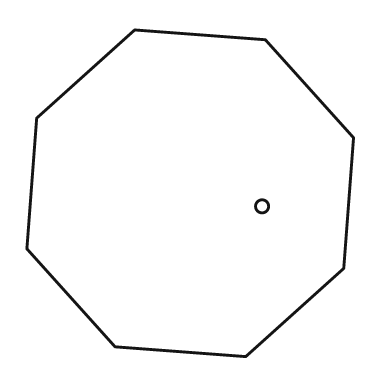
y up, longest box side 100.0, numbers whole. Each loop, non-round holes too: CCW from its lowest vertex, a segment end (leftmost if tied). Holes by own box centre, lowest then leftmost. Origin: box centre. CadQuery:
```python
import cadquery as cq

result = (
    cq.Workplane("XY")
    .moveTo(17.0, -50.0)
    .lineTo(47.0, -23.0)
    .lineTo(50.0, 17.0)
    .lineTo(23.0, 47.0)
    .lineTo(-17.0, 50.0)
    .lineTo(-47.0, 23.0)
    .lineTo(-50.0, -17.0)
    .lineTo(-23.0, -47.0)
    .close()
    .moveTo(22.0, -4.0)
    .circle(2.0)
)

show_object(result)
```